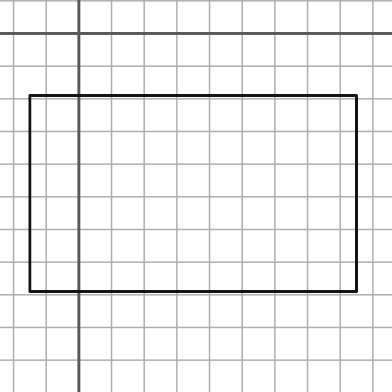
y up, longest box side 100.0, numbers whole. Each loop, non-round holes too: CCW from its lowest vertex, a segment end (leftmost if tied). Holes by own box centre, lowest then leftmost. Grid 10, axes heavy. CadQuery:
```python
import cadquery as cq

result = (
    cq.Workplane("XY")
    .moveTo(-15.0, -79.0)
    .lineTo(85.0, -79.0)
    .lineTo(85.0, -19.0)
    .lineTo(-15.0, -19.0)
    .close()
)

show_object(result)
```